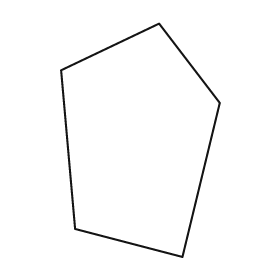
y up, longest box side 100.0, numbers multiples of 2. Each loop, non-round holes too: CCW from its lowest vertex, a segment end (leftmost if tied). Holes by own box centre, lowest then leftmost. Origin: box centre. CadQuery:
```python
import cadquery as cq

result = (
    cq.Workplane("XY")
    .moveTo(18.0, -50.0)
    .lineTo(34.0, 16.0)
    .lineTo(8.0, 50.0)
    .lineTo(-34.0, 30.0)
    .lineTo(-28.0, -38.0)
    .close()
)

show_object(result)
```